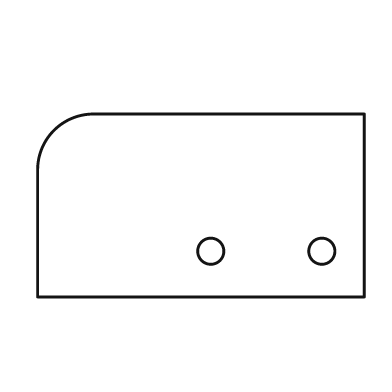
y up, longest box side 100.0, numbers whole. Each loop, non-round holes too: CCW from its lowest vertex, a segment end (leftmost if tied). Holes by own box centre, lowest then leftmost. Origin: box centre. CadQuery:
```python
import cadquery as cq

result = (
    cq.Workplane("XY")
    .moveTo(-50.0, -28.0)
    .lineTo(50.0, -28.0)
    .lineTo(50.0, 28.0)
    .lineTo(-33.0, 28.0)
    .threePointArc((-45.0, 23.0), (-50.0, 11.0))
    .close()
    .moveTo(3.0, -14.0)
    .circle(4.0)
    .moveTo(37.0, -14.0)
    .circle(4.0)
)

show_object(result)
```